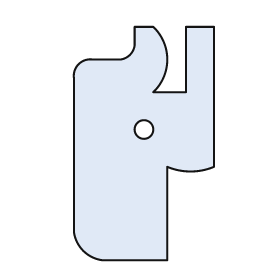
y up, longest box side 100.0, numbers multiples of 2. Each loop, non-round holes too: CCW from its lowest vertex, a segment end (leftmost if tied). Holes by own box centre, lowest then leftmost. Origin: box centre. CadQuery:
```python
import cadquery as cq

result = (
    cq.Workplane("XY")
    .moveTo(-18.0, -50.0)
    .lineTo(10.0, -50.0)
    .lineTo(10.0, -10.0)
    .threePointArc((20.0, -12.0), (30.0, -10.0))
    .lineTo(30.0, 50.0)
    .lineTo(18.0, 50.0)
    .lineTo(18.0, 22.0)
    .lineTo(4.0, 22.0)
    .threePointArc((10.0, 36.0), (4.0, 50.0))
    .lineTo(-4.0, 50.0)
    .lineTo(-4.0, 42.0)
    .threePointArc((-6.0, 38.0), (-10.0, 36.0))
    .lineTo(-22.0, 36.0)
    .threePointArc((-28.0, 34.0), (-30.0, 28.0))
    .lineTo(-30.0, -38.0)
    .threePointArc((-26.0, -46.0), (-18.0, -50.0))
    .close()
    .moveTo(0.0, 6.0)
    .circle(4.0)
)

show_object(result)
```